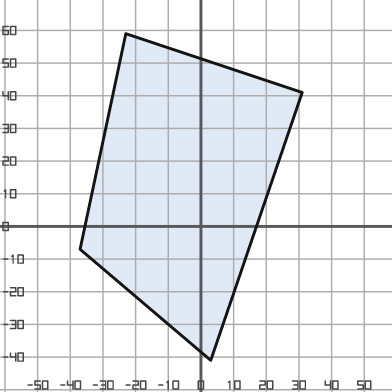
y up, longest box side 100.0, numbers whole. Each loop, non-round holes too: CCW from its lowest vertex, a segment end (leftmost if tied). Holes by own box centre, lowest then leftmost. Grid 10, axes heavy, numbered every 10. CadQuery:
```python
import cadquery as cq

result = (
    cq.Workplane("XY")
    .moveTo(3.0, -41.0)
    .lineTo(31.0, 41.0)
    .lineTo(-23.0, 59.0)
    .lineTo(-37.0, -7.0)
    .close()
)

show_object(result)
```